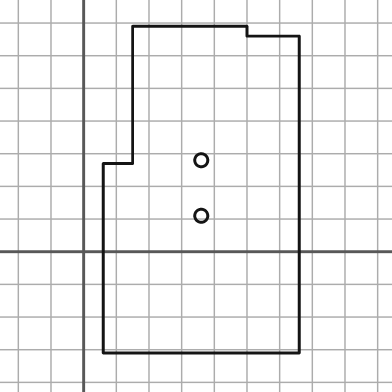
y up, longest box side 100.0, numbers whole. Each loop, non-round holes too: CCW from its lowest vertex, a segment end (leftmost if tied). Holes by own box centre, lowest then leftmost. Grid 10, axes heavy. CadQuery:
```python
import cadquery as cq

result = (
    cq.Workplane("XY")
    .moveTo(6.0, -31.0)
    .lineTo(66.0, -31.0)
    .lineTo(66.0, 66.0)
    .lineTo(50.0, 66.0)
    .lineTo(50.0, 69.0)
    .lineTo(15.0, 69.0)
    .lineTo(15.0, 27.0)
    .lineTo(6.0, 27.0)
    .close()
    .moveTo(36.0, 11.0)
    .circle(2.0)
    .moveTo(36.0, 28.0)
    .circle(2.0)
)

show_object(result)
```